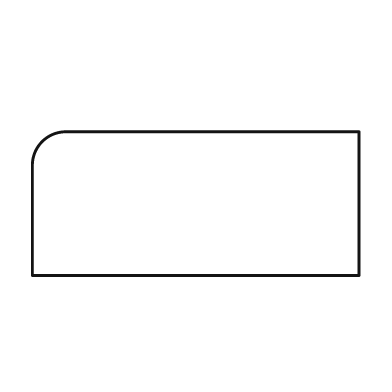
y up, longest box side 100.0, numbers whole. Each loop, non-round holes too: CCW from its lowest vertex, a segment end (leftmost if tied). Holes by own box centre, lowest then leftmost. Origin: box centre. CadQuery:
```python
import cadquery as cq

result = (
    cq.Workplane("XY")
    .moveTo(-50.0, -22.0)
    .lineTo(50.0, -22.0)
    .lineTo(50.0, 22.0)
    .lineTo(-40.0, 22.0)
    .threePointArc((-47.0, 19.0), (-50.0, 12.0))
    .close()
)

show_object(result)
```